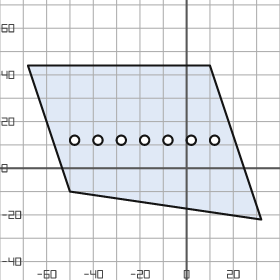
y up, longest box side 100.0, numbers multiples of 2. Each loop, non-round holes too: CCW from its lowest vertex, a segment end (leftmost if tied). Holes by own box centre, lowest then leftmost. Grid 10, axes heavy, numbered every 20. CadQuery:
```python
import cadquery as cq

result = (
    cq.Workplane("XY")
    .moveTo(32.0, -22.0)
    .lineTo(10.0, 44.0)
    .lineTo(-68.0, 44.0)
    .lineTo(-50.0, -10.0)
    .close()
    .moveTo(-48.0, 12.0)
    .circle(2.0)
    .moveTo(-38.0, 12.0)
    .circle(2.0)
    .moveTo(-28.0, 12.0)
    .circle(2.0)
    .moveTo(-18.0, 12.0)
    .circle(2.0)
    .moveTo(-8.0, 12.0)
    .circle(2.0)
    .moveTo(2.0, 12.0)
    .circle(2.0)
    .moveTo(12.0, 12.0)
    .circle(2.0)
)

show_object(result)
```